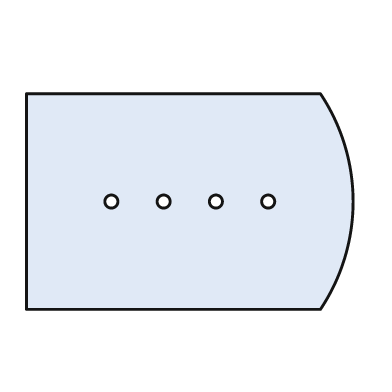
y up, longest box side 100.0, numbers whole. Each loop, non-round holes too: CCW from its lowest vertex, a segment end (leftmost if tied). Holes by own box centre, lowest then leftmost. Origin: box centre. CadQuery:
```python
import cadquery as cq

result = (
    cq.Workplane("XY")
    .moveTo(-50.0, -33.0)
    .lineTo(40.0, -33.0)
    .threePointArc((50.0, 0.0), (40.0, 33.0))
    .lineTo(-50.0, 33.0)
    .close()
    .moveTo(-24.0, 0.0)
    .circle(2.0)
    .moveTo(-8.0, 0.0)
    .circle(2.0)
    .moveTo(8.0, 0.0)
    .circle(2.0)
    .moveTo(24.0, 0.0)
    .circle(2.0)
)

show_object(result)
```